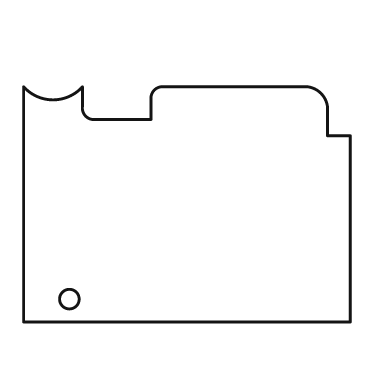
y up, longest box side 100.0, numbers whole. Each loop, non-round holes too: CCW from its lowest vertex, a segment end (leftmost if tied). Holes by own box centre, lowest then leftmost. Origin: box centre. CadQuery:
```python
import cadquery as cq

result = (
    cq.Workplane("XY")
    .moveTo(-50.0, -36.0)
    .lineTo(50.0, -36.0)
    .lineTo(50.0, 21.0)
    .lineTo(43.0, 21.0)
    .lineTo(43.0, 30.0)
    .threePointArc((41.0, 34.0), (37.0, 36.0))
    .lineTo(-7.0, 36.0)
    .threePointArc((-10.0, 35.0), (-11.0, 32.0))
    .lineTo(-11.0, 26.0)
    .lineTo(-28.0, 26.0)
    .threePointArc((-31.0, 27.0), (-32.0, 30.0))
    .lineTo(-32.0, 36.0)
    .threePointArc((-41.0, 32.0), (-50.0, 36.0))
    .close()
    .moveTo(-36.0, -29.0)
    .circle(3.0)
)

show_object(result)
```